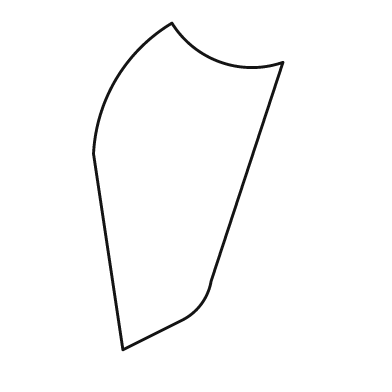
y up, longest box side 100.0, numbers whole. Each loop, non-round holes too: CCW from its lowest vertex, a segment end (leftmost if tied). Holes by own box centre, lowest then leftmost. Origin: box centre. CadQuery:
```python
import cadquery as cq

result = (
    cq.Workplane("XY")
    .moveTo(-20.0, -50.0)
    .lineTo(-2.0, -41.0)
    .threePointArc((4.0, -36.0), (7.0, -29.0))
    .lineTo(29.0, 38.0)
    .threePointArc((10.0, 38.0), (-5.0, 50.0))
    .threePointArc((-22.0, 33.0), (-29.0, 10.0))
    .close()
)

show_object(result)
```